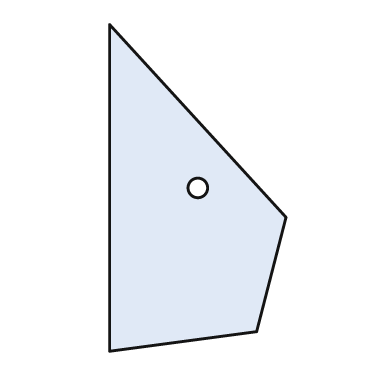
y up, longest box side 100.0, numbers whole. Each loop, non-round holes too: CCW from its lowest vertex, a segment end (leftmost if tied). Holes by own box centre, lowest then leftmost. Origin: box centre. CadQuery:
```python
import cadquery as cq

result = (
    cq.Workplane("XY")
    .moveTo(-27.0, -50.0)
    .lineTo(18.0, -44.0)
    .lineTo(27.0, -9.0)
    .lineTo(-27.0, 50.0)
    .close()
    .moveTo(0.0, 0.0)
    .circle(3.0)
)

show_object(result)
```